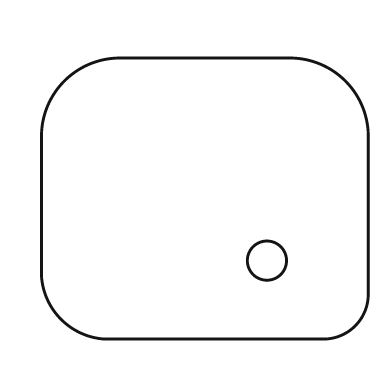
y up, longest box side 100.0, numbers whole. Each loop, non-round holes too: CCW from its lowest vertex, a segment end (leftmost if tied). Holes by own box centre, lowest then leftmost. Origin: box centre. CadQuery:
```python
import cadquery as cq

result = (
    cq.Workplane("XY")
    .moveTo(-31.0, -43.0)
    .lineTo(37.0, -43.0)
    .threePointArc((46.0, -39.0), (50.0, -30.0))
    .lineTo(50.0, 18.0)
    .threePointArc((43.0, 36.0), (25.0, 43.0))
    .lineTo(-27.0, 43.0)
    .threePointArc((-43.0, 36.0), (-50.0, 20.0))
    .lineTo(-50.0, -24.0)
    .threePointArc((-44.0, -37.0), (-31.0, -43.0))
    .close()
    .moveTo(19.0, -19.0)
    .circle(6.0)
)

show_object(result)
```